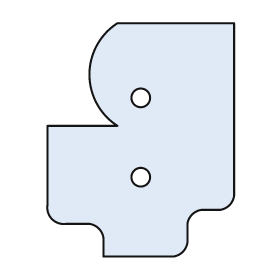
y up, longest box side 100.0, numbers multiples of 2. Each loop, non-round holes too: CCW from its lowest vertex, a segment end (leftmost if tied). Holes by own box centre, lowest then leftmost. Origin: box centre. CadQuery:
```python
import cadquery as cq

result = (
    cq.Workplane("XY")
    .moveTo(-16.0, -50.0)
    .lineTo(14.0, -50.0)
    .threePointArc((18.0, -48.0), (20.0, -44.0))
    .lineTo(20.0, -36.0)
    .threePointArc((22.0, -32.0), (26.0, -30.0))
    .lineTo(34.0, -30.0)
    .threePointArc((38.0, -28.0), (40.0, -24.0))
    .lineTo(40.0, 50.0)
    .lineTo(-10.0, 50.0)
    .threePointArc((-22.0, 28.0), (-10.0, 6.0))
    .lineTo(-40.0, 6.0)
    .lineTo(-40.0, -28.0)
    .threePointArc((-38.0, -34.0), (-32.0, -36.0))
    .lineTo(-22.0, -36.0)
    .threePointArc((-18.0, -38.0), (-16.0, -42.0))
    .close()
    .moveTo(0.0, -16.0)
    .circle(4.0)
    .moveTo(0.0, 18.0)
    .circle(4.0)
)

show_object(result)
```